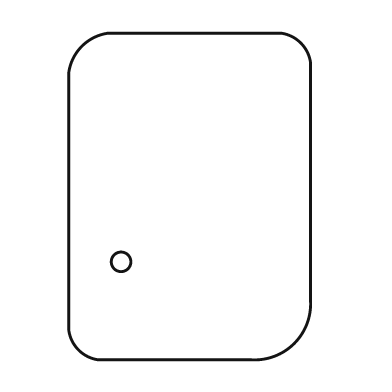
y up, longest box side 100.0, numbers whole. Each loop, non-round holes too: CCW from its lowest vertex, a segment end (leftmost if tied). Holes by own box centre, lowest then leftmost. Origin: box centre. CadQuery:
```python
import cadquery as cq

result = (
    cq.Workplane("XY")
    .moveTo(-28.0, -50.0)
    .lineTo(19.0, -50.0)
    .threePointArc((32.0, -45.0), (37.0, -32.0))
    .lineTo(37.0, 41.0)
    .threePointArc((34.0, 47.0), (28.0, 50.0))
    .lineTo(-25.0, 50.0)
    .threePointArc((-33.0, 46.0), (-37.0, 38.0))
    .lineTo(-37.0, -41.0)
    .threePointArc((-34.0, -47.0), (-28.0, -50.0))
    .close()
    .moveTo(-21.0, -20.0)
    .circle(3.0)
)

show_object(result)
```